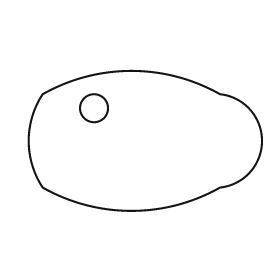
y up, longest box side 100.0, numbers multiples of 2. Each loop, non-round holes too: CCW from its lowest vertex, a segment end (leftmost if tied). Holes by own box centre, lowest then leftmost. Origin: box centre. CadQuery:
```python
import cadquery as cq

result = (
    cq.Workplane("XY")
    .moveTo(-44.0, -20.0)
    .threePointArc((-6.0, -30.0), (32.0, -20.0))
    .threePointArc((50.0, 0.0), (32.0, 20.0))
    .threePointArc((-6.0, 30.0), (-44.0, 20.0))
    .threePointArc((-50.0, 0.0), (-44.0, -20.0))
    .close()
    .moveTo(-22.0, 14.0)
    .circle(6.0)
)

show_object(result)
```